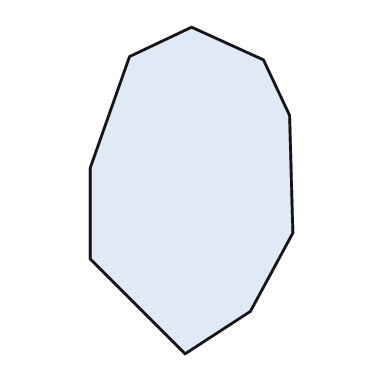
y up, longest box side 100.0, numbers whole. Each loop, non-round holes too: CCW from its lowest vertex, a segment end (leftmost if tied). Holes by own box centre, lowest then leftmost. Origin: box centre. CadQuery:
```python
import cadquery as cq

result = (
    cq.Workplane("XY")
    .moveTo(-2.0, -50.0)
    .lineTo(18.0, -37.0)
    .lineTo(31.0, -13.0)
    .lineTo(30.0, 23.0)
    .lineTo(22.0, 40.0)
    .lineTo(0.0, 50.0)
    .lineTo(-19.0, 41.0)
    .lineTo(-31.0, 7.0)
    .lineTo(-31.0, -21.0)
    .close()
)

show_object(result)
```